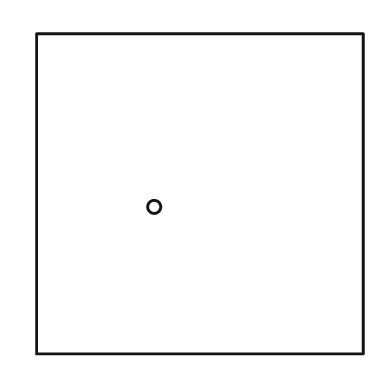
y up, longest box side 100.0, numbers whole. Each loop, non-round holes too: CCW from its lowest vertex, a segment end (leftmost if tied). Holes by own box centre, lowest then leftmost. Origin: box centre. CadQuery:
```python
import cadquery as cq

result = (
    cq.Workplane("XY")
    .moveTo(-50.0, -49.0)
    .lineTo(50.0, -49.0)
    .lineTo(50.0, 49.0)
    .lineTo(-50.0, 49.0)
    .close()
    .moveTo(-14.0, -4.0)
    .circle(2.0)
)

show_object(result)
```